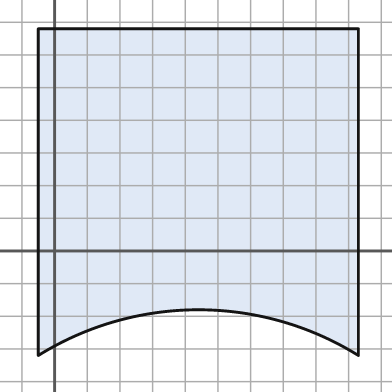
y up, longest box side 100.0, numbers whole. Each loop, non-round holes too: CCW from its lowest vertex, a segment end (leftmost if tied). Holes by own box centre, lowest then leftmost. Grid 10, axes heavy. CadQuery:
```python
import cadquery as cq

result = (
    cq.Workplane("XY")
    .moveTo(-5.0, -32.0)
    .threePointArc((44.0, -18.0), (93.0, -32.0))
    .lineTo(93.0, 68.0)
    .lineTo(-5.0, 68.0)
    .close()
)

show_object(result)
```